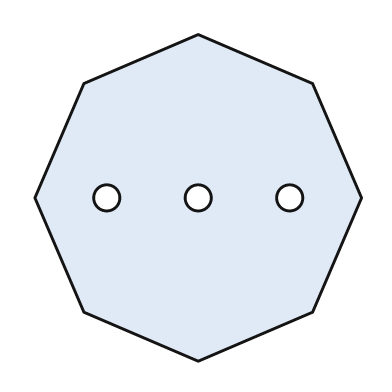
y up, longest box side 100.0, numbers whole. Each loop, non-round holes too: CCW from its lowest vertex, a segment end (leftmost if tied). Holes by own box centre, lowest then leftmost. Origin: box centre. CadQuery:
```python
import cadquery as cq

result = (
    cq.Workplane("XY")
    .moveTo(0.0, -50.0)
    .lineTo(35.0, -35.0)
    .lineTo(50.0, 0.0)
    .lineTo(35.0, 35.0)
    .lineTo(0.0, 50.0)
    .lineTo(-35.0, 35.0)
    .lineTo(-50.0, 0.0)
    .lineTo(-35.0, -35.0)
    .close()
    .moveTo(-28.0, 0.0)
    .circle(4.0)
    .moveTo(0.0, 0.0)
    .circle(4.0)
    .moveTo(28.0, 0.0)
    .circle(4.0)
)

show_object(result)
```